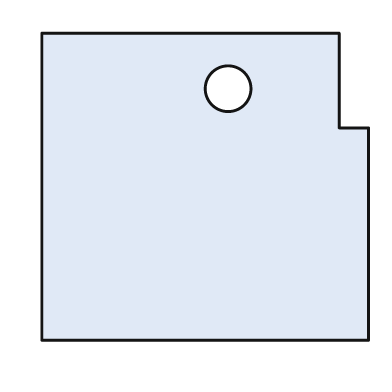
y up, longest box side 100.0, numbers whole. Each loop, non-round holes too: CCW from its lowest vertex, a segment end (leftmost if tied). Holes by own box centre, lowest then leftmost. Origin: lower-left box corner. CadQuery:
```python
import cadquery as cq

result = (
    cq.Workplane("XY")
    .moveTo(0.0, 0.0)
    .lineTo(100.0, 0.0)
    .lineTo(100.0, 65.0)
    .lineTo(91.0, 65.0)
    .lineTo(91.0, 94.0)
    .lineTo(0.0, 94.0)
    .close()
    .moveTo(57.0, 77.0)
    .circle(7.0)
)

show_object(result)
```